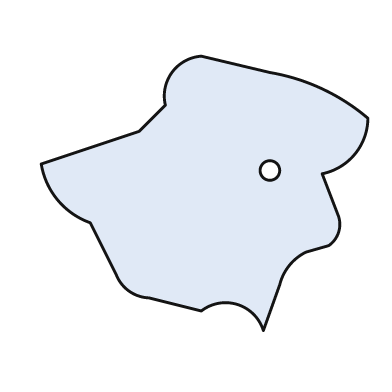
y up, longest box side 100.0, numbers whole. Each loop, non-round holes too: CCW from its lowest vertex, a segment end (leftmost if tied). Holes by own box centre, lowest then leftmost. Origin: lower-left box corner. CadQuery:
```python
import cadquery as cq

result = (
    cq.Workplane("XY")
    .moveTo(68.0, 0.0)
    .lineTo(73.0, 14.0)
    .threePointArc((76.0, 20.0), (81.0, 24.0))
    .lineTo(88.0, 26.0)
    .threePointArc((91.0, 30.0), (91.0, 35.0))
    .lineTo(86.0, 48.0)
    .threePointArc((96.0, 54.0), (100.0, 65.0))
    .threePointArc((86.0, 74.0), (70.0, 79.0))
    .lineTo(49.0, 84.0)
    .threePointArc((40.0, 79.0), (38.0, 69.0))
    .lineTo(30.0, 61.0)
    .lineTo(0.0, 51.0)
    .threePointArc((5.0, 40.0), (15.0, 33.0))
    .lineTo(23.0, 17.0)
    .threePointArc((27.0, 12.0), (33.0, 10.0))
    .lineTo(49.0, 6.0)
    .threePointArc((60.0, 8.0), (68.0, 0.0))
    .close()
    .moveTo(70.0, 49.0)
    .circle(3.0)
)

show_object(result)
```